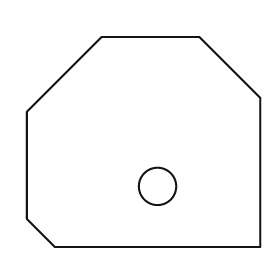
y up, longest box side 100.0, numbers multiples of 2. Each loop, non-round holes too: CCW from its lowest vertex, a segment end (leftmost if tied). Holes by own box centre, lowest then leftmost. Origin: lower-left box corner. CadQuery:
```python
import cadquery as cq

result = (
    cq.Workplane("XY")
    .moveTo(12.0, 0.0)
    .lineTo(100.0, 0.0)
    .lineTo(100.0, 64.0)
    .lineTo(74.0, 90.0)
    .lineTo(32.0, 90.0)
    .lineTo(0.0, 58.0)
    .lineTo(0.0, 12.0)
    .close()
    .moveTo(56.0, 26.0)
    .circle(8.0)
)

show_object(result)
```